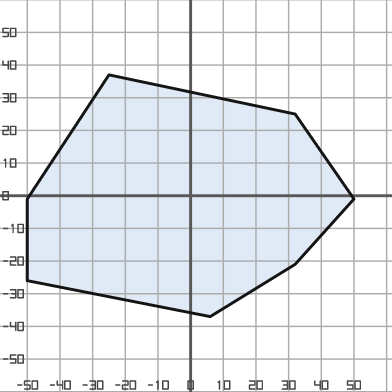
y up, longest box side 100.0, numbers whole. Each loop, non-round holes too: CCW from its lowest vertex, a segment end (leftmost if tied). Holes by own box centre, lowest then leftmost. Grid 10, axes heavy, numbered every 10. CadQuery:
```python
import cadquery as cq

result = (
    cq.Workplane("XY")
    .moveTo(6.0, -37.0)
    .lineTo(32.0, -21.0)
    .lineTo(50.0, -1.0)
    .lineTo(32.0, 25.0)
    .lineTo(-25.0, 37.0)
    .lineTo(-50.0, -1.0)
    .lineTo(-50.0, -26.0)
    .close()
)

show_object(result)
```